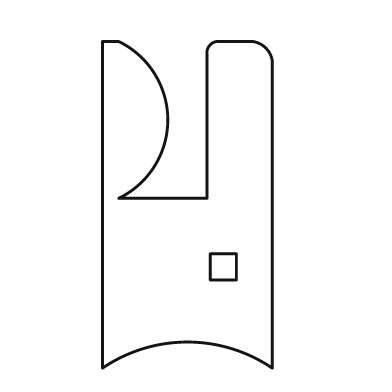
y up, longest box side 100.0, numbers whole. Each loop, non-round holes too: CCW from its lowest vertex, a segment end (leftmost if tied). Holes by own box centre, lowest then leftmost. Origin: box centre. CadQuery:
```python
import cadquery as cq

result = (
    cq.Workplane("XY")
    .moveTo(-26.0, -50.0)
    .threePointArc((0.0, -42.0), (26.0, -50.0))
    .lineTo(26.0, 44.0)
    .threePointArc((24.0, 48.0), (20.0, 50.0))
    .lineTo(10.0, 50.0)
    .threePointArc((7.0, 49.0), (6.0, 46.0))
    .lineTo(6.0, 2.0)
    .lineTo(-21.0, 2.0)
    .threePointArc((-6.0, 26.0), (-21.0, 50.0))
    .lineTo(-26.0, 50.0)
    .close()
    .moveTo(7.0, -23.0)
    .lineTo(15.0, -23.0)
    .lineTo(15.0, -15.0)
    .lineTo(7.0, -15.0)
    .close()
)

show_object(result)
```